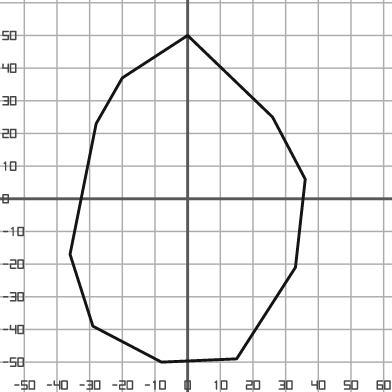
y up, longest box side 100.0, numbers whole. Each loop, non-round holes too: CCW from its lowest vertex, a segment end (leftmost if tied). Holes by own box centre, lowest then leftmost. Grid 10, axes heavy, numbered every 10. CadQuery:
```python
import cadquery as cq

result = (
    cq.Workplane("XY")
    .moveTo(-8.0, -50.0)
    .lineTo(15.0, -49.0)
    .lineTo(33.0, -21.0)
    .lineTo(36.0, 6.0)
    .lineTo(26.0, 25.0)
    .lineTo(0.0, 50.0)
    .lineTo(-20.0, 37.0)
    .lineTo(-28.0, 23.0)
    .lineTo(-36.0, -17.0)
    .lineTo(-29.0, -39.0)
    .close()
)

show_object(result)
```